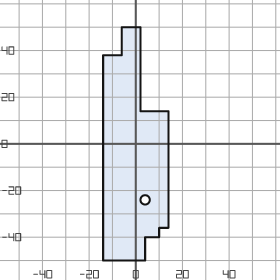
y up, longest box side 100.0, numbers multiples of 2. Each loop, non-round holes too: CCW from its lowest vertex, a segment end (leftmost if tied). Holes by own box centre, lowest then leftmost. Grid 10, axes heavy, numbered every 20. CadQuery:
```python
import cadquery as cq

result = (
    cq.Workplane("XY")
    .moveTo(-14.0, -50.0)
    .lineTo(4.0, -50.0)
    .lineTo(4.0, -40.0)
    .lineTo(10.0, -40.0)
    .lineTo(10.0, -36.0)
    .lineTo(14.0, -36.0)
    .lineTo(14.0, 14.0)
    .lineTo(2.0, 14.0)
    .lineTo(2.0, 50.0)
    .lineTo(-6.0, 50.0)
    .lineTo(-6.0, 38.0)
    .lineTo(-14.0, 38.0)
    .close()
    .moveTo(4.0, -24.0)
    .circle(2.0)
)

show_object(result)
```